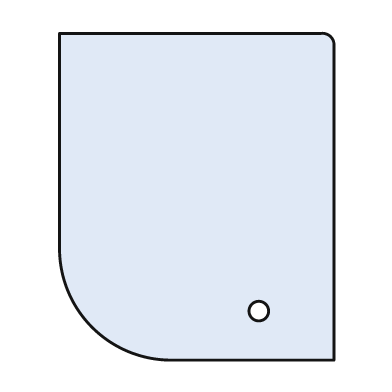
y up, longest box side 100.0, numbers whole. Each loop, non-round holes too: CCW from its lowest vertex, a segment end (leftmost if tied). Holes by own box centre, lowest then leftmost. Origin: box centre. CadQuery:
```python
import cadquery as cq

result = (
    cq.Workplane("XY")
    .moveTo(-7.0, -50.0)
    .lineTo(42.0, -50.0)
    .lineTo(42.0, 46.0)
    .threePointArc((41.0, 49.0), (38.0, 50.0))
    .lineTo(-42.0, 50.0)
    .lineTo(-42.0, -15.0)
    .threePointArc((-32.0, -40.0), (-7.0, -50.0))
    .close()
    .moveTo(19.0, -35.0)
    .circle(3.0)
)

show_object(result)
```